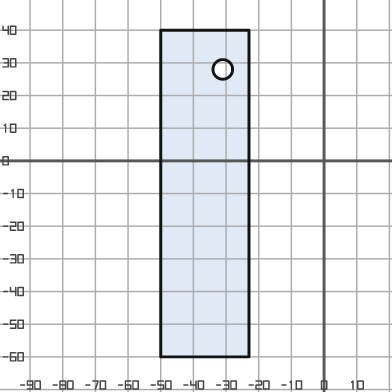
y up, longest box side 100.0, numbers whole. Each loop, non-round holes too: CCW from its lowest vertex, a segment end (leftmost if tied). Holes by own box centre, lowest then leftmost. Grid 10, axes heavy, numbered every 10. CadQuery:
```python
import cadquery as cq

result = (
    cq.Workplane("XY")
    .moveTo(-50.0, -60.0)
    .lineTo(-23.0, -60.0)
    .lineTo(-23.0, 40.0)
    .lineTo(-50.0, 40.0)
    .close()
    .moveTo(-31.0, 28.0)
    .circle(3.0)
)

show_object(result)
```